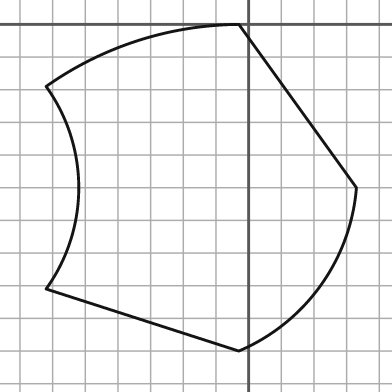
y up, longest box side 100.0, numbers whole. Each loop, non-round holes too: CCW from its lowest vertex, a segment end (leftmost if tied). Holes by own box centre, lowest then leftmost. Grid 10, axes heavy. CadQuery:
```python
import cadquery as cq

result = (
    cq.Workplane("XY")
    .moveTo(-3.0, -100.0)
    .threePointArc((22.0, -80.0), (33.0, -50.0))
    .lineTo(-3.0, 0.0)
    .threePointArc((-34.0, -5.0), (-62.0, -19.0))
    .threePointArc((-52.0, -50.0), (-62.0, -81.0))
    .close()
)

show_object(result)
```